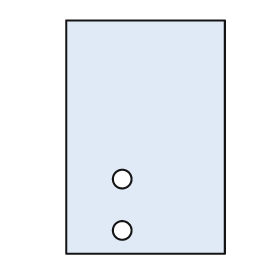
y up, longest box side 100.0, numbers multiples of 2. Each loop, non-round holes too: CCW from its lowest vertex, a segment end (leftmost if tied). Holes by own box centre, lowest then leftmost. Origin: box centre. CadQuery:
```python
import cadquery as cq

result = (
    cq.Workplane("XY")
    .moveTo(-34.0, -50.0)
    .lineTo(34.0, -50.0)
    .lineTo(34.0, 50.0)
    .lineTo(-34.0, 50.0)
    .close()
    .moveTo(-10.0, -40.0)
    .circle(4.0)
    .moveTo(-10.0, -18.0)
    .circle(4.0)
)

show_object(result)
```